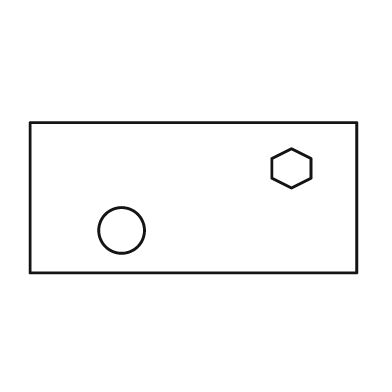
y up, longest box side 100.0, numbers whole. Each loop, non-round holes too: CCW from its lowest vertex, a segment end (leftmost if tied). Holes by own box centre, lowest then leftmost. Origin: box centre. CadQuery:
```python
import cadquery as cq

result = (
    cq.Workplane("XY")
    .moveTo(-50.0, -23.0)
    .lineTo(50.0, -23.0)
    .lineTo(50.0, 23.0)
    .lineTo(-50.0, 23.0)
    .close()
    .moveTo(-22.0, -10.0)
    .circle(7.0)
    .moveTo(30.0, 3.0)
    .lineTo(36.0, 6.0)
    .lineTo(36.0, 12.0)
    .lineTo(30.0, 15.0)
    .lineTo(24.0, 12.0)
    .lineTo(24.0, 6.0)
    .close()
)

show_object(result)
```